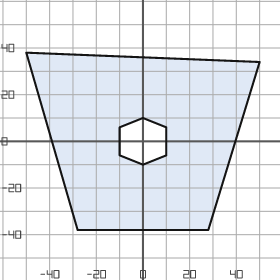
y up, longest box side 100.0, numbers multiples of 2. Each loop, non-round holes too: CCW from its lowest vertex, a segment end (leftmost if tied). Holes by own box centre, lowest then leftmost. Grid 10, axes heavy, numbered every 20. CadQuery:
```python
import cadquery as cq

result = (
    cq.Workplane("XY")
    .moveTo(-28.0, -38.0)
    .lineTo(28.0, -38.0)
    .lineTo(50.0, 34.0)
    .lineTo(-50.0, 38.0)
    .close()
    .moveTo(0.0, -10.0)
    .lineTo(10.0, -6.0)
    .lineTo(10.0, 6.0)
    .lineTo(0.0, 10.0)
    .lineTo(-10.0, 6.0)
    .lineTo(-10.0, -6.0)
    .close()
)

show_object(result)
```